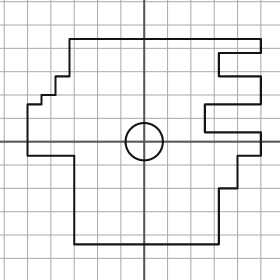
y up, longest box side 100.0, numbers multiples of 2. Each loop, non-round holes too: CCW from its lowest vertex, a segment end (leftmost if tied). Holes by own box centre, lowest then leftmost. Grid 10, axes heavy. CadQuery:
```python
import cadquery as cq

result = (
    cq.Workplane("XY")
    .moveTo(-30.0, -44.0)
    .lineTo(32.0, -44.0)
    .lineTo(32.0, -20.0)
    .lineTo(40.0, -20.0)
    .lineTo(40.0, -6.0)
    .lineTo(50.0, -6.0)
    .lineTo(50.0, 4.0)
    .lineTo(26.0, 4.0)
    .lineTo(26.0, 16.0)
    .lineTo(50.0, 16.0)
    .lineTo(50.0, 28.0)
    .lineTo(32.0, 28.0)
    .lineTo(32.0, 38.0)
    .lineTo(50.0, 38.0)
    .lineTo(50.0, 44.0)
    .lineTo(-32.0, 44.0)
    .lineTo(-32.0, 28.0)
    .lineTo(-38.0, 28.0)
    .lineTo(-38.0, 20.0)
    .lineTo(-44.0, 20.0)
    .lineTo(-44.0, 16.0)
    .lineTo(-50.0, 16.0)
    .lineTo(-50.0, -6.0)
    .lineTo(-30.0, -6.0)
    .close()
    .moveTo(0.0, 0.0)
    .circle(8.0)
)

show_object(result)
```